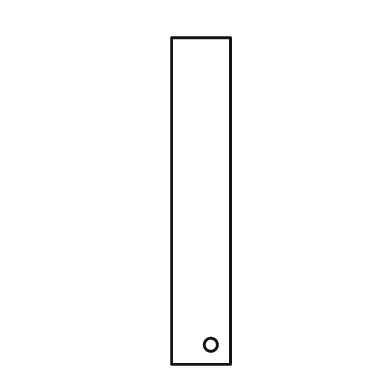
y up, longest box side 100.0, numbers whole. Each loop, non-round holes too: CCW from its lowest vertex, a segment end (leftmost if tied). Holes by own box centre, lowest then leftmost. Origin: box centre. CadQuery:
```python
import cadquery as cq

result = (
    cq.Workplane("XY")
    .moveTo(-9.0, -50.0)
    .lineTo(9.0, -50.0)
    .lineTo(9.0, 50.0)
    .lineTo(-9.0, 50.0)
    .close()
    .moveTo(3.0, -44.0)
    .circle(2.0)
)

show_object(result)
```